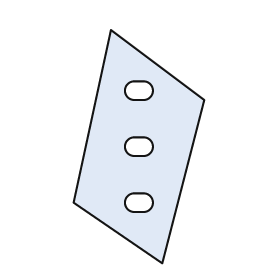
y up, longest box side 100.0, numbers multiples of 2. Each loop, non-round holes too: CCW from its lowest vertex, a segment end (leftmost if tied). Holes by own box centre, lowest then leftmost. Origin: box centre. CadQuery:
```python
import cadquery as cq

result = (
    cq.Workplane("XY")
    .moveTo(10.0, -50.0)
    .lineTo(28.0, 20.0)
    .lineTo(-12.0, 50.0)
    .lineTo(-28.0, -24.0)
    .close()
    .moveTo(-2.0, -28.0)
    .lineTo(2.0, -28.0)
    .threePointArc((6.0, -24.0), (2.0, -20.0))
    .lineTo(-2.0, -20.0)
    .threePointArc((-6.0, -24.0), (-2.0, -28.0))
    .close()
    .moveTo(-2.0, -4.0)
    .lineTo(2.0, -4.0)
    .threePointArc((6.0, 0.0), (2.0, 4.0))
    .lineTo(-2.0, 4.0)
    .threePointArc((-6.0, 0.0), (-2.0, -4.0))
    .close()
    .moveTo(-2.0, 20.0)
    .lineTo(2.0, 20.0)
    .threePointArc((6.0, 24.0), (2.0, 28.0))
    .lineTo(-2.0, 28.0)
    .threePointArc((-6.0, 24.0), (-2.0, 20.0))
    .close()
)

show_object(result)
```